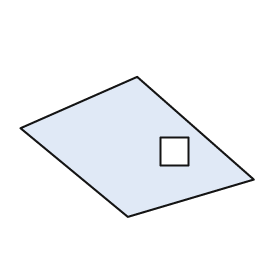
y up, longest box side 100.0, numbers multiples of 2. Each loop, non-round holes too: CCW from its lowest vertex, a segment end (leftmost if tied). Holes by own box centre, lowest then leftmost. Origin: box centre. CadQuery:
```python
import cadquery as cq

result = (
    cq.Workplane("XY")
    .moveTo(-4.0, -30.0)
    .lineTo(50.0, -14.0)
    .lineTo(0.0, 30.0)
    .lineTo(-50.0, 8.0)
    .close()
    .moveTo(10.0, -8.0)
    .lineTo(22.0, -8.0)
    .lineTo(22.0, 4.0)
    .lineTo(10.0, 4.0)
    .close()
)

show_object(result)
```